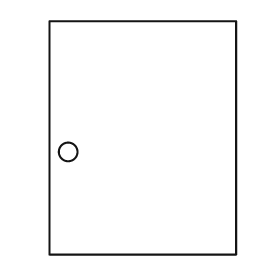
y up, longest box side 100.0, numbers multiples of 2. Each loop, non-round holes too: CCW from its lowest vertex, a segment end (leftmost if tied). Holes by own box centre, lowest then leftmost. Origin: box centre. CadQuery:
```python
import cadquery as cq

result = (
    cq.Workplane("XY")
    .moveTo(-40.0, -50.0)
    .lineTo(40.0, -50.0)
    .lineTo(40.0, 50.0)
    .lineTo(-40.0, 50.0)
    .close()
    .moveTo(-32.0, -6.0)
    .circle(4.0)
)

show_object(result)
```